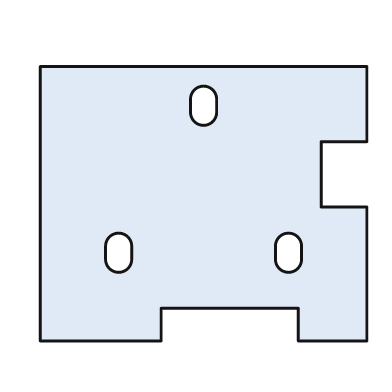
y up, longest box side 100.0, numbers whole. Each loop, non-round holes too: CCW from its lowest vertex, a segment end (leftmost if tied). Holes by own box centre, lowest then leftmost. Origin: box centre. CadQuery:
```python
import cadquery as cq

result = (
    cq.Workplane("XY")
    .moveTo(-50.0, -42.0)
    .lineTo(-13.0, -42.0)
    .lineTo(-13.0, -32.0)
    .lineTo(29.0, -32.0)
    .lineTo(29.0, -42.0)
    .lineTo(50.0, -42.0)
    .lineTo(50.0, -1.0)
    .lineTo(36.0, -1.0)
    .lineTo(36.0, 19.0)
    .lineTo(50.0, 19.0)
    .lineTo(50.0, 42.0)
    .lineTo(-50.0, 42.0)
    .close()
    .moveTo(-30.0, -17.0)
    .threePointArc((-26.0, -21.0), (-22.0, -17.0))
    .lineTo(-22.0, -13.0)
    .threePointArc((-26.0, -9.0), (-30.0, -13.0))
    .close()
    .moveTo(22.0, -17.0)
    .threePointArc((26.0, -21.0), (30.0, -17.0))
    .lineTo(30.0, -13.0)
    .threePointArc((26.0, -9.0), (22.0, -13.0))
    .close()
    .moveTo(-4.0, 28.0)
    .threePointArc((0.0, 24.0), (4.0, 28.0))
    .lineTo(4.0, 32.0)
    .threePointArc((0.0, 36.0), (-4.0, 32.0))
    .close()
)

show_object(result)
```